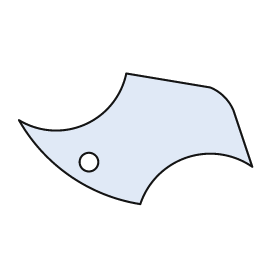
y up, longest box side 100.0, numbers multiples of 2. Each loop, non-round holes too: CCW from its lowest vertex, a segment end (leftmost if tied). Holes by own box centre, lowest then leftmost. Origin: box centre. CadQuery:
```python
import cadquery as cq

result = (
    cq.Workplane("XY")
    .moveTo(2.0, -28.0)
    .threePointArc((22.0, -8.0), (50.0, -12.0))
    .lineTo(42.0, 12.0)
    .threePointArc((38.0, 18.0), (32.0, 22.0))
    .lineTo(-4.0, 28.0)
    .threePointArc((-22.0, 6.0), (-50.0, 8.0))
    .threePointArc((-28.0, -16.0), (2.0, -28.0))
    .close()
    .moveTo(-20.0, -10.0)
    .circle(4.0)
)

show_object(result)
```